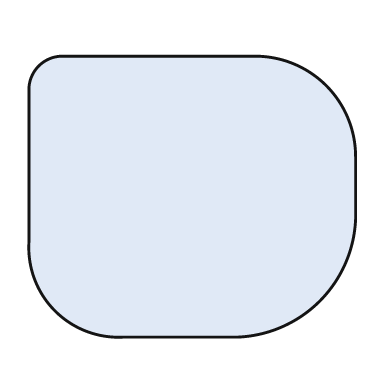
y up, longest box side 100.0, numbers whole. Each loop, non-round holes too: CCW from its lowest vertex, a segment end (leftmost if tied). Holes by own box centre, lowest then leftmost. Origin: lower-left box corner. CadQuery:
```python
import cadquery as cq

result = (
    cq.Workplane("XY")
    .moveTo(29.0, 0.0)
    .lineTo(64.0, 0.0)
    .threePointArc((89.0, 11.0), (100.0, 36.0))
    .lineTo(100.0, 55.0)
    .threePointArc((91.0, 77.0), (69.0, 86.0))
    .lineTo(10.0, 86.0)
    .threePointArc((3.0, 83.0), (0.0, 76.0))
    .lineTo(0.0, 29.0)
    .threePointArc((8.0, 8.0), (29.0, 0.0))
    .close()
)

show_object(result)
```